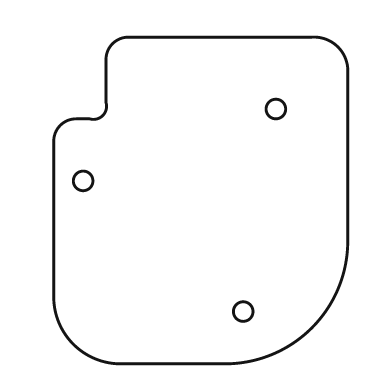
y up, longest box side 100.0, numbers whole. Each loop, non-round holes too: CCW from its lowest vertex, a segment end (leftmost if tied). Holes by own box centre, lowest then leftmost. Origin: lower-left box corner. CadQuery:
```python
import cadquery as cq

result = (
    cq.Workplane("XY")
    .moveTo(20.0, 0.0)
    .lineTo(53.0, 0.0)
    .threePointArc((79.0, 11.0), (90.0, 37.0))
    .lineTo(90.0, 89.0)
    .threePointArc((87.0, 97.0), (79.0, 100.0))
    .lineTo(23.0, 100.0)
    .threePointArc((18.0, 98.0), (16.0, 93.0))
    .lineTo(16.0, 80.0)
    .threePointArc((15.0, 76.0), (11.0, 75.0))
    .lineTo(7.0, 75.0)
    .threePointArc((2.0, 73.0), (0.0, 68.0))
    .lineTo(0.0, 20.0)
    .threePointArc((6.0, 6.0), (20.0, 0.0))
    .close()
    .moveTo(58.0, 16.0)
    .circle(3.0)
    .moveTo(9.0, 56.0)
    .circle(3.0)
    .moveTo(68.0, 78.0)
    .circle(3.0)
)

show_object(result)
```